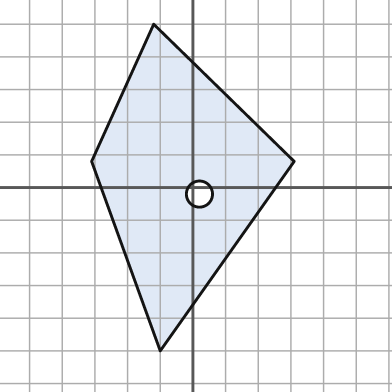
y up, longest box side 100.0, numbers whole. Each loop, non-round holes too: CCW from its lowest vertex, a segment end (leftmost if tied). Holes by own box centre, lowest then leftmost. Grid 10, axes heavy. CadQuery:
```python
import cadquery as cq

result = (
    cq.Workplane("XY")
    .moveTo(-10.0, -50.0)
    .lineTo(31.0, 8.0)
    .lineTo(-12.0, 50.0)
    .lineTo(-31.0, 8.0)
    .close()
    .moveTo(2.0, -2.0)
    .circle(4.0)
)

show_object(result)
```